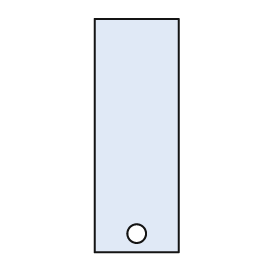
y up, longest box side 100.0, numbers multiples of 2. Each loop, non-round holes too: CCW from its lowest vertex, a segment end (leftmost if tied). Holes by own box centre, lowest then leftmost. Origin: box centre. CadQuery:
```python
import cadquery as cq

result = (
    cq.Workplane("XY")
    .moveTo(-18.0, -50.0)
    .lineTo(18.0, -50.0)
    .lineTo(18.0, 50.0)
    .lineTo(-18.0, 50.0)
    .close()
    .moveTo(0.0, -42.0)
    .circle(4.0)
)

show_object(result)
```